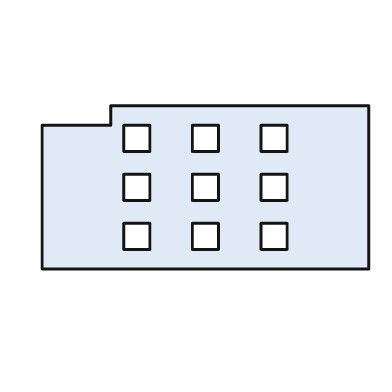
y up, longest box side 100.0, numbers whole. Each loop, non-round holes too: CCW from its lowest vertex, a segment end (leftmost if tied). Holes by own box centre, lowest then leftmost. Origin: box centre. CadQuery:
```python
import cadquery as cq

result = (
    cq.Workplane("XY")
    .moveTo(-50.0, -25.0)
    .lineTo(50.0, -25.0)
    .lineTo(50.0, 25.0)
    .lineTo(-29.0, 25.0)
    .lineTo(-29.0, 19.0)
    .lineTo(-50.0, 19.0)
    .close()
    .moveTo(-25.0, -19.0)
    .lineTo(-17.0, -19.0)
    .lineTo(-17.0, -11.0)
    .lineTo(-25.0, -11.0)
    .close()
    .moveTo(-4.0, -19.0)
    .lineTo(4.0, -19.0)
    .lineTo(4.0, -11.0)
    .lineTo(-4.0, -11.0)
    .close()
    .moveTo(17.0, -19.0)
    .lineTo(25.0, -19.0)
    .lineTo(25.0, -11.0)
    .lineTo(17.0, -11.0)
    .close()
    .moveTo(-25.0, -4.0)
    .lineTo(-17.0, -4.0)
    .lineTo(-17.0, 4.0)
    .lineTo(-25.0, 4.0)
    .close()
    .moveTo(-4.0, -4.0)
    .lineTo(4.0, -4.0)
    .lineTo(4.0, 4.0)
    .lineTo(-4.0, 4.0)
    .close()
    .moveTo(17.0, -4.0)
    .lineTo(25.0, -4.0)
    .lineTo(25.0, 4.0)
    .lineTo(17.0, 4.0)
    .close()
    .moveTo(-25.0, 11.0)
    .lineTo(-17.0, 11.0)
    .lineTo(-17.0, 19.0)
    .lineTo(-25.0, 19.0)
    .close()
    .moveTo(-4.0, 11.0)
    .lineTo(4.0, 11.0)
    .lineTo(4.0, 19.0)
    .lineTo(-4.0, 19.0)
    .close()
    .moveTo(17.0, 11.0)
    .lineTo(25.0, 11.0)
    .lineTo(25.0, 19.0)
    .lineTo(17.0, 19.0)
    .close()
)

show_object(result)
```